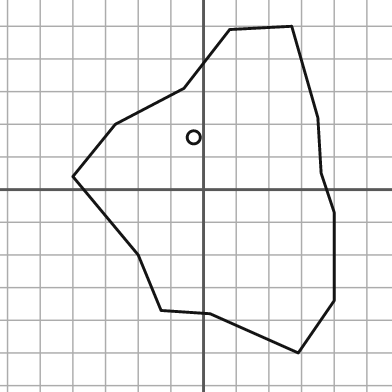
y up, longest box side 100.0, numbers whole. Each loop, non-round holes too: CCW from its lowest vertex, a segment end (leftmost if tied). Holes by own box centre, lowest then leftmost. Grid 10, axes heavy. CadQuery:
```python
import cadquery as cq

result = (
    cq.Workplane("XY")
    .moveTo(29.0, -50.0)
    .lineTo(40.0, -34.0)
    .lineTo(40.0, -7.0)
    .lineTo(36.0, 5.0)
    .lineTo(35.0, 22.0)
    .lineTo(27.0, 50.0)
    .lineTo(8.0, 49.0)
    .lineTo(-6.0, 31.0)
    .lineTo(-27.0, 20.0)
    .lineTo(-40.0, 4.0)
    .lineTo(-20.0, -20.0)
    .lineTo(-13.0, -37.0)
    .lineTo(2.0, -38.0)
    .close()
    .moveTo(-3.0, 16.0)
    .circle(2.0)
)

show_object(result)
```